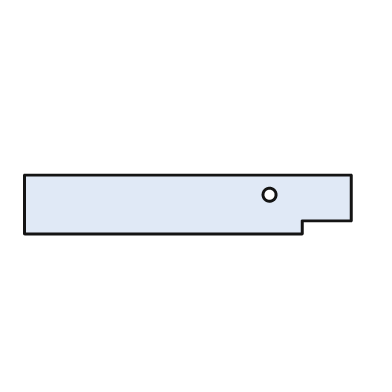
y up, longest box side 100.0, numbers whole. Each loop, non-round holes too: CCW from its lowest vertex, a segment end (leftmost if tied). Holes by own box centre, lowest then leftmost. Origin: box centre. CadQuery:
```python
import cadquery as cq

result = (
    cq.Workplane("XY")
    .moveTo(-50.0, -9.0)
    .lineTo(35.0, -9.0)
    .lineTo(35.0, -5.0)
    .lineTo(50.0, -5.0)
    .lineTo(50.0, 9.0)
    .lineTo(-50.0, 9.0)
    .close()
    .moveTo(25.0, 3.0)
    .circle(2.0)
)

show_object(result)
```